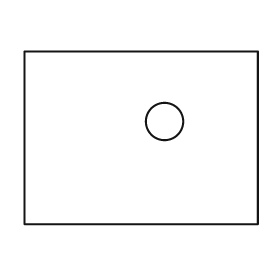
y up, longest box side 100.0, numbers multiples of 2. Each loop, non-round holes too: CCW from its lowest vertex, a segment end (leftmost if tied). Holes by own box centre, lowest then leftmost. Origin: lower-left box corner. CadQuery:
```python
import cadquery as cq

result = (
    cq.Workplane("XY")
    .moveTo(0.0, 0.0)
    .lineTo(100.0, 0.0)
    .lineTo(100.0, 74.0)
    .lineTo(0.0, 74.0)
    .close()
    .moveTo(60.0, 44.0)
    .circle(8.0)
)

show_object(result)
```